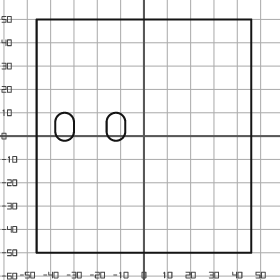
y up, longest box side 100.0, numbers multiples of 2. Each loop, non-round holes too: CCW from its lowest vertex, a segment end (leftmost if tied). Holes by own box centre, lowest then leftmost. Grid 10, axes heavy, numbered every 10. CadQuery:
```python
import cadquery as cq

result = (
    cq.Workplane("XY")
    .moveTo(-46.0, -50.0)
    .lineTo(46.0, -50.0)
    .lineTo(46.0, 50.0)
    .lineTo(-46.0, 50.0)
    .close()
    .moveTo(-38.0, 2.0)
    .threePointArc((-34.0, -2.0), (-30.0, 2.0))
    .lineTo(-30.0, 6.0)
    .threePointArc((-34.0, 10.0), (-38.0, 6.0))
    .close()
    .moveTo(-16.0, 2.0)
    .threePointArc((-12.0, -2.0), (-8.0, 2.0))
    .lineTo(-8.0, 6.0)
    .threePointArc((-12.0, 10.0), (-16.0, 6.0))
    .close()
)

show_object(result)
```